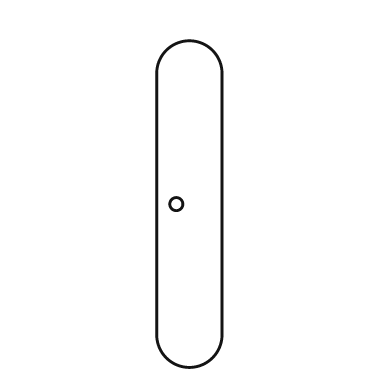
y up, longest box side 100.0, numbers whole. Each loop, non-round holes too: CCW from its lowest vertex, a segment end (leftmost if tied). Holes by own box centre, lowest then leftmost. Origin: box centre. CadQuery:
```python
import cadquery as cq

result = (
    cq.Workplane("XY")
    .moveTo(-10.0, -40.0)
    .threePointArc((0.0, -50.0), (10.0, -40.0))
    .lineTo(10.0, 40.0)
    .threePointArc((0.0, 50.0), (-10.0, 40.0))
    .close()
    .moveTo(-4.0, 0.0)
    .circle(2.0)
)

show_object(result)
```